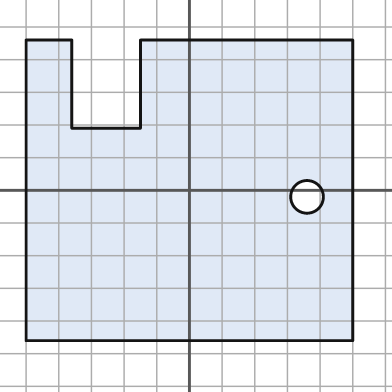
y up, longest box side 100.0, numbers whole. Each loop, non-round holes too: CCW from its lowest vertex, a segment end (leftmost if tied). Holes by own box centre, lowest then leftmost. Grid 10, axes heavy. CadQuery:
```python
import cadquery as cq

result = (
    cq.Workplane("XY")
    .moveTo(-50.0, -46.0)
    .lineTo(50.0, -46.0)
    .lineTo(50.0, 46.0)
    .lineTo(-15.0, 46.0)
    .lineTo(-15.0, 19.0)
    .lineTo(-36.0, 19.0)
    .lineTo(-36.0, 46.0)
    .lineTo(-50.0, 46.0)
    .close()
    .moveTo(36.0, -2.0)
    .circle(5.0)
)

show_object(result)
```